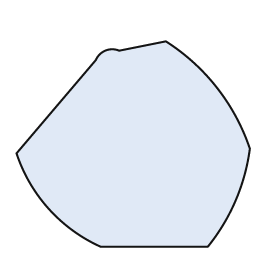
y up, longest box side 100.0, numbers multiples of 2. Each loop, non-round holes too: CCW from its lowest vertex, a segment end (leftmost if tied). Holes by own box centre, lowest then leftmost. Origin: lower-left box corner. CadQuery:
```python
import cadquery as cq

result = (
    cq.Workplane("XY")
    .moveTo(36.0, 0.0)
    .lineTo(82.0, 0.0)
    .threePointArc((94.0, 20.0), (100.0, 42.0))
    .threePointArc((86.0, 68.0), (64.0, 88.0))
    .lineTo(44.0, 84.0)
    .threePointArc((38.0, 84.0), (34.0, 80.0))
    .lineTo(0.0, 40.0)
    .threePointArc((14.0, 16.0), (36.0, 0.0))
    .close()
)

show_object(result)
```